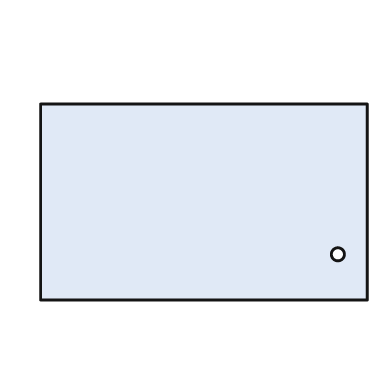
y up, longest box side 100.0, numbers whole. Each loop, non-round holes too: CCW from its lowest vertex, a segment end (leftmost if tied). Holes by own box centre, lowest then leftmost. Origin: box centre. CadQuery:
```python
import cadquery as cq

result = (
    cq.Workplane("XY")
    .moveTo(-50.0, -30.0)
    .lineTo(50.0, -30.0)
    .lineTo(50.0, 30.0)
    .lineTo(-50.0, 30.0)
    .close()
    .moveTo(41.0, -16.0)
    .circle(2.0)
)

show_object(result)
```